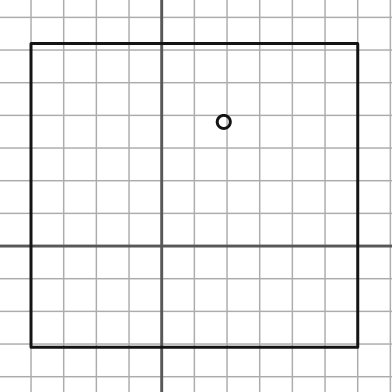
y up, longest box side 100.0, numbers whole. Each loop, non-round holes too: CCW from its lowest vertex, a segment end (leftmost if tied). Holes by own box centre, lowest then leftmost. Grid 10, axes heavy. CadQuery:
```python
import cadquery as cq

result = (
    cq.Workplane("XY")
    .moveTo(-40.0, -31.0)
    .lineTo(60.0, -31.0)
    .lineTo(60.0, 62.0)
    .lineTo(-40.0, 62.0)
    .close()
    .moveTo(19.0, 38.0)
    .circle(2.0)
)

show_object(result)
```